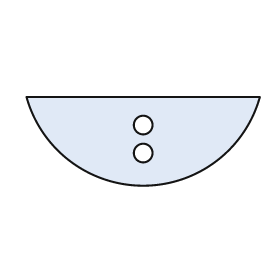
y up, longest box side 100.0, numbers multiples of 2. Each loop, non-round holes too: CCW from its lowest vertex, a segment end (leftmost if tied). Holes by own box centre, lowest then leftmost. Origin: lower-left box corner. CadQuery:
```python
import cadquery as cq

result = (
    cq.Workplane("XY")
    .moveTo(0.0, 38.0)
    .threePointArc((50.0, 0.0), (100.0, 38.0))
    .close()
    .moveTo(50.0, 14.0)
    .circle(4.0)
    .moveTo(50.0, 26.0)
    .circle(4.0)
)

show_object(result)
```